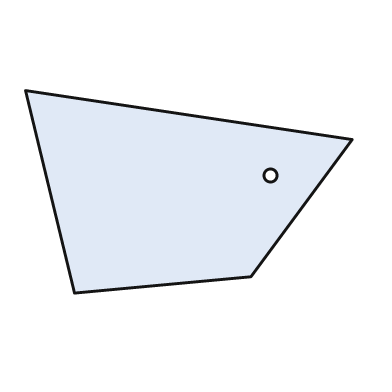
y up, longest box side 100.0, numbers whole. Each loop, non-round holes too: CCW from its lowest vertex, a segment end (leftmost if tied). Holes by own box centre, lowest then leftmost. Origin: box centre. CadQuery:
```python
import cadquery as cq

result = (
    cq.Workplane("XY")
    .moveTo(-35.0, -31.0)
    .lineTo(19.0, -26.0)
    .lineTo(50.0, 16.0)
    .lineTo(-50.0, 31.0)
    .close()
    .moveTo(25.0, 5.0)
    .circle(2.0)
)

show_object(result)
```